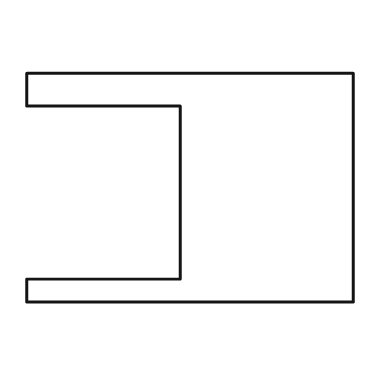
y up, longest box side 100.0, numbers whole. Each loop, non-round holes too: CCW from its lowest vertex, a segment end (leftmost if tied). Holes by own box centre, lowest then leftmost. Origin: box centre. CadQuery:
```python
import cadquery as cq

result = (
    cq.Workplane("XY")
    .moveTo(-50.0, -35.0)
    .lineTo(50.0, -35.0)
    .lineTo(50.0, 35.0)
    .lineTo(-50.0, 35.0)
    .lineTo(-50.0, 25.0)
    .lineTo(-3.0, 25.0)
    .lineTo(-3.0, -28.0)
    .lineTo(-50.0, -28.0)
    .close()
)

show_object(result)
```